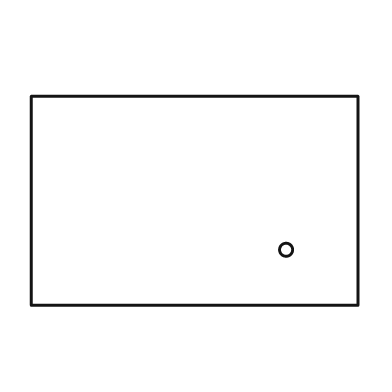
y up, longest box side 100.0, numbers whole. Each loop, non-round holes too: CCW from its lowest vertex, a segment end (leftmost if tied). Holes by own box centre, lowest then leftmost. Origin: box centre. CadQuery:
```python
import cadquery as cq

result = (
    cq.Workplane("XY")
    .moveTo(-50.0, -32.0)
    .lineTo(50.0, -32.0)
    .lineTo(50.0, 32.0)
    .lineTo(-50.0, 32.0)
    .close()
    .moveTo(28.0, -15.0)
    .circle(2.0)
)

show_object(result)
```